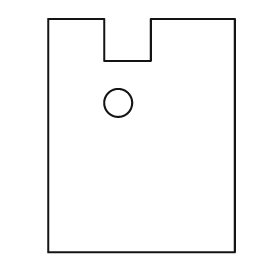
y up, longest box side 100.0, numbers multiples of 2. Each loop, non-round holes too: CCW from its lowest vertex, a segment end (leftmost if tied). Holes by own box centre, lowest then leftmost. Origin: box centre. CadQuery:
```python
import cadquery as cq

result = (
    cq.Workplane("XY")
    .moveTo(-40.0, -50.0)
    .lineTo(40.0, -50.0)
    .lineTo(40.0, 50.0)
    .lineTo(4.0, 50.0)
    .lineTo(4.0, 32.0)
    .lineTo(-16.0, 32.0)
    .lineTo(-16.0, 50.0)
    .lineTo(-40.0, 50.0)
    .close()
    .moveTo(-10.0, 14.0)
    .circle(6.0)
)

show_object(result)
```